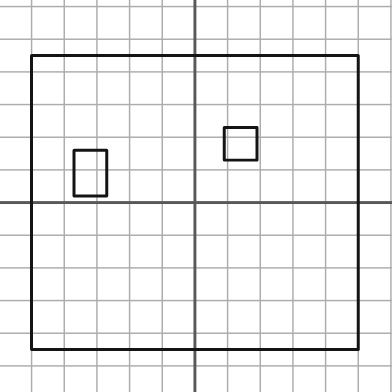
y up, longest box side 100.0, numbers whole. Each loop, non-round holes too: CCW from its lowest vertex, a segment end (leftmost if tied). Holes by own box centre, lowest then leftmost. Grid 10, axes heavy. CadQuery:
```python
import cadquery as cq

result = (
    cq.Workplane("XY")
    .moveTo(-50.0, -45.0)
    .lineTo(50.0, -45.0)
    .lineTo(50.0, 45.0)
    .lineTo(-50.0, 45.0)
    .close()
    .moveTo(-37.0, 2.0)
    .lineTo(-27.0, 2.0)
    .lineTo(-27.0, 16.0)
    .lineTo(-37.0, 16.0)
    .close()
    .moveTo(9.0, 13.0)
    .lineTo(19.0, 13.0)
    .lineTo(19.0, 23.0)
    .lineTo(9.0, 23.0)
    .close()
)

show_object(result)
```